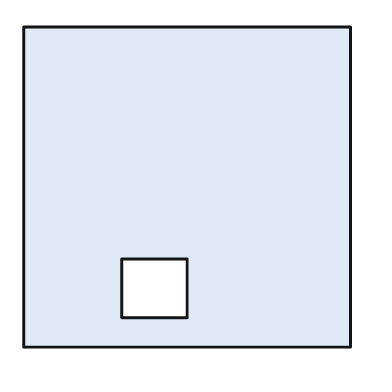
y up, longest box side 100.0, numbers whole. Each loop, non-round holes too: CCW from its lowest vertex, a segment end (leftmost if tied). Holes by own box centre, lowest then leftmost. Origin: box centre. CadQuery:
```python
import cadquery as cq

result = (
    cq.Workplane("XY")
    .moveTo(-50.0, -49.0)
    .lineTo(50.0, -49.0)
    .lineTo(50.0, 49.0)
    .lineTo(-50.0, 49.0)
    .close()
    .moveTo(-20.0, -40.0)
    .lineTo(0.0, -40.0)
    .lineTo(0.0, -22.0)
    .lineTo(-20.0, -22.0)
    .close()
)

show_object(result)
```